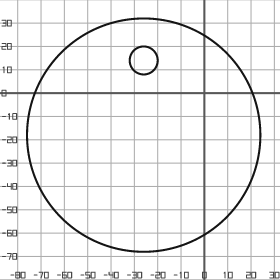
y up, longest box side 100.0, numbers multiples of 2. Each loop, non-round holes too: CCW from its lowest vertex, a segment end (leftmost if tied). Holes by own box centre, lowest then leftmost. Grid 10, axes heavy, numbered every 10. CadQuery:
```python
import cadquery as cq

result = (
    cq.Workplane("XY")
    .moveTo(-26.0, -18.0)
    .circle(50.0)
    .moveTo(-26.0, 14.0)
    .circle(6.0)
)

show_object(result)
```